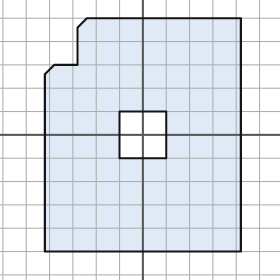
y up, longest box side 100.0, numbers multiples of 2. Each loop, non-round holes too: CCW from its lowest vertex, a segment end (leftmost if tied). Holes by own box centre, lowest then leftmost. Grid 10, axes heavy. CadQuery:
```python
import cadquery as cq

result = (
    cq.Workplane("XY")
    .moveTo(-42.0, -50.0)
    .lineTo(42.0, -50.0)
    .lineTo(42.0, 50.0)
    .lineTo(-24.0, 50.0)
    .lineTo(-28.0, 46.0)
    .lineTo(-28.0, 30.0)
    .lineTo(-38.0, 30.0)
    .lineTo(-42.0, 26.0)
    .close()
    .moveTo(-10.0, -10.0)
    .lineTo(10.0, -10.0)
    .lineTo(10.0, 10.0)
    .lineTo(-10.0, 10.0)
    .close()
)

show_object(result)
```